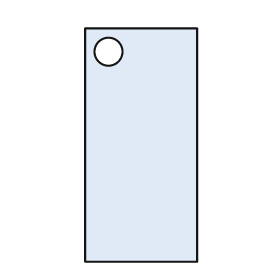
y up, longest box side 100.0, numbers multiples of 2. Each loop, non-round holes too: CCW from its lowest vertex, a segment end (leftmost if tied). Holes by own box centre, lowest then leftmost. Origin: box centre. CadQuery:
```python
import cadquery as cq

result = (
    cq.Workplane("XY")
    .moveTo(-24.0, -50.0)
    .lineTo(24.0, -50.0)
    .lineTo(24.0, 50.0)
    .lineTo(-24.0, 50.0)
    .close()
    .moveTo(-14.0, 40.0)
    .circle(6.0)
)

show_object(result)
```